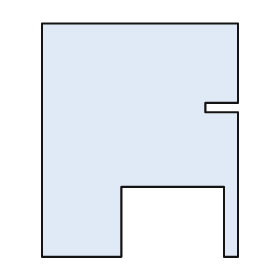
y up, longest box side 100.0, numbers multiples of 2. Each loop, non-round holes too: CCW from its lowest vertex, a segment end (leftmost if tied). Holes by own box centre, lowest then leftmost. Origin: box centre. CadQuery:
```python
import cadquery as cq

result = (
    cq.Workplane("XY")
    .moveTo(-42.0, -50.0)
    .lineTo(-8.0, -50.0)
    .lineTo(-8.0, -20.0)
    .lineTo(36.0, -20.0)
    .lineTo(36.0, -50.0)
    .lineTo(42.0, -50.0)
    .lineTo(42.0, 12.0)
    .lineTo(28.0, 12.0)
    .lineTo(28.0, 16.0)
    .lineTo(42.0, 16.0)
    .lineTo(42.0, 50.0)
    .lineTo(-42.0, 50.0)
    .close()
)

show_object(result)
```